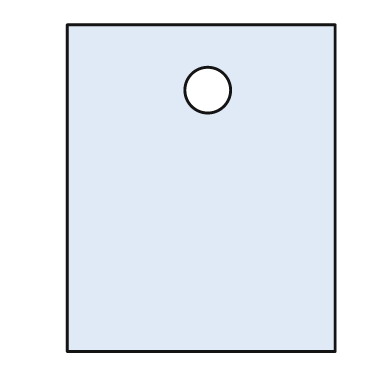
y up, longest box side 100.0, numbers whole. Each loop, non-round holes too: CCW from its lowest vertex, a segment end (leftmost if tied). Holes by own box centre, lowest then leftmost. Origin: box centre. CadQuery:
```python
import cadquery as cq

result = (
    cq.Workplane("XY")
    .moveTo(-41.0, -50.0)
    .lineTo(41.0, -50.0)
    .lineTo(41.0, 50.0)
    .lineTo(-41.0, 50.0)
    .close()
    .moveTo(2.0, 30.0)
    .circle(7.0)
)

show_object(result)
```